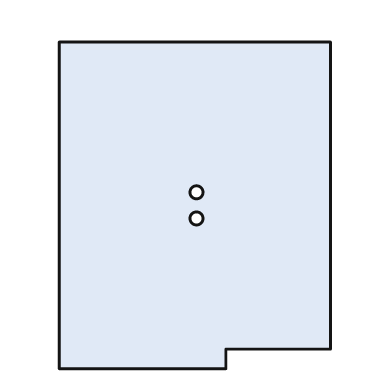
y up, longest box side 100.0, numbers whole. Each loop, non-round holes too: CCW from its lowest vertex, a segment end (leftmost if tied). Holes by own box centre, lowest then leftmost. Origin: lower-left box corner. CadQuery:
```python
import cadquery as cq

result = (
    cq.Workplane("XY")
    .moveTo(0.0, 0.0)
    .lineTo(51.0, 0.0)
    .lineTo(51.0, 6.0)
    .lineTo(83.0, 6.0)
    .lineTo(83.0, 100.0)
    .lineTo(0.0, 100.0)
    .close()
    .moveTo(42.0, 46.0)
    .circle(2.0)
    .moveTo(42.0, 54.0)
    .circle(2.0)
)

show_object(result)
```